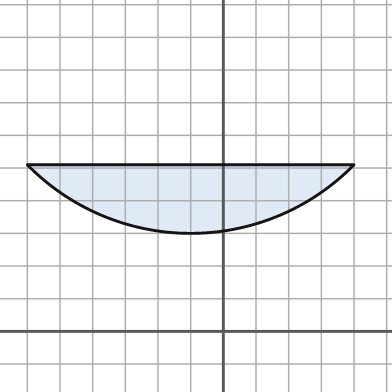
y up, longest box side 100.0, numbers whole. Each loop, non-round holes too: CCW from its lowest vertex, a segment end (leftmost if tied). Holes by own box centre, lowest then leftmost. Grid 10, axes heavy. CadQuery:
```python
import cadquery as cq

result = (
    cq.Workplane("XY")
    .moveTo(-60.0, 51.0)
    .threePointArc((-10.0, 30.0), (40.0, 51.0))
    .close()
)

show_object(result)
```